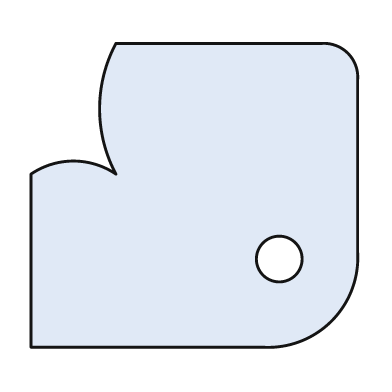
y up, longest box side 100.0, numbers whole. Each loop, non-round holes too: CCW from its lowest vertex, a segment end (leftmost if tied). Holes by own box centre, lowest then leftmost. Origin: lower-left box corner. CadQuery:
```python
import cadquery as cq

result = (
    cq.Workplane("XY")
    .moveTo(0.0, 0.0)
    .lineTo(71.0, 0.0)
    .threePointArc((92.0, 8.0), (100.0, 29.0))
    .lineTo(100.0, 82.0)
    .threePointArc((97.0, 90.0), (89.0, 93.0))
    .lineTo(26.0, 93.0)
    .threePointArc((21.0, 73.0), (26.0, 53.0))
    .threePointArc((13.0, 57.0), (0.0, 53.0))
    .close()
    .moveTo(76.0, 27.0)
    .circle(7.0)
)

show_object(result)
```